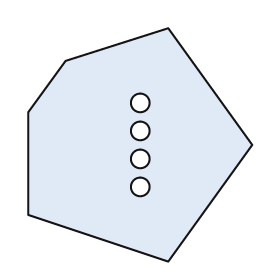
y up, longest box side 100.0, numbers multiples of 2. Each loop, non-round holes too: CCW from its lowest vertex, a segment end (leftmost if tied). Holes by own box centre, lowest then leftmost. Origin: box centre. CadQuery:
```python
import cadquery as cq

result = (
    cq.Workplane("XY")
    .moveTo(12.0, -50.0)
    .lineTo(48.0, 0.0)
    .lineTo(12.0, 50.0)
    .lineTo(-32.0, 36.0)
    .lineTo(-48.0, 14.0)
    .lineTo(-48.0, -30.0)
    .close()
    .moveTo(0.0, -18.0)
    .circle(4.0)
    .moveTo(0.0, -6.0)
    .circle(4.0)
    .moveTo(0.0, 6.0)
    .circle(4.0)
    .moveTo(0.0, 18.0)
    .circle(4.0)
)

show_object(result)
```